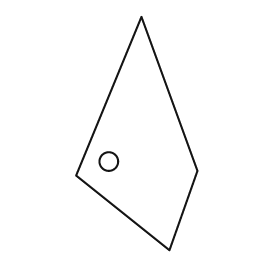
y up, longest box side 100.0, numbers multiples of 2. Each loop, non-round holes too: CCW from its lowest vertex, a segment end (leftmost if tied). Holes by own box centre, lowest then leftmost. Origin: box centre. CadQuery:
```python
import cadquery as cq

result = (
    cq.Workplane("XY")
    .moveTo(14.0, -50.0)
    .lineTo(26.0, -16.0)
    .lineTo(2.0, 50.0)
    .lineTo(-26.0, -18.0)
    .close()
    .moveTo(-12.0, -12.0)
    .circle(4.0)
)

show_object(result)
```